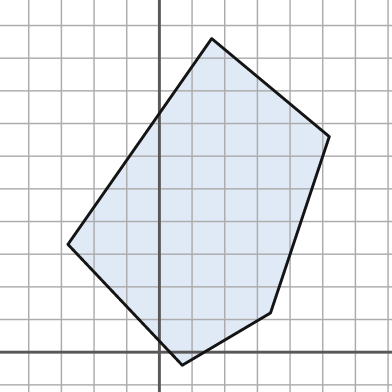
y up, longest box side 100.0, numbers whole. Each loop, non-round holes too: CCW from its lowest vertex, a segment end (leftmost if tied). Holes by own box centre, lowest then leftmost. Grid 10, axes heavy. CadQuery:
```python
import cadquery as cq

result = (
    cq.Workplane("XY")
    .moveTo(7.0, -4.0)
    .lineTo(34.0, 12.0)
    .lineTo(52.0, 66.0)
    .lineTo(16.0, 96.0)
    .lineTo(-28.0, 33.0)
    .close()
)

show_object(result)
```